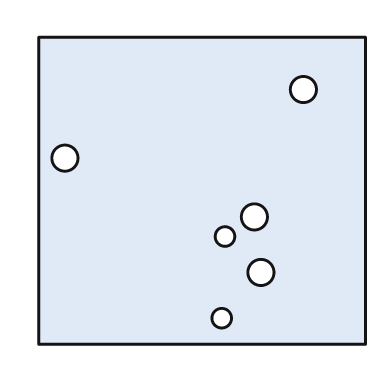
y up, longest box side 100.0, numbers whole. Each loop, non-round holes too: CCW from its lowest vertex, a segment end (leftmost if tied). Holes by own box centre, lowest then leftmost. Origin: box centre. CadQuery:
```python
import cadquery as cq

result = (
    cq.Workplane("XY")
    .moveTo(-50.0, -47.0)
    .lineTo(50.0, -47.0)
    .lineTo(50.0, 47.0)
    .lineTo(-50.0, 47.0)
    .close()
    .moveTo(6.0, -39.0)
    .circle(3.0)
    .moveTo(18.0, -25.0)
    .circle(4.0)
    .moveTo(7.0, -14.0)
    .circle(3.0)
    .moveTo(16.0, -8.0)
    .circle(4.0)
    .moveTo(-42.0, 10.0)
    .circle(4.0)
    .moveTo(31.0, 31.0)
    .circle(4.0)
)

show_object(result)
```